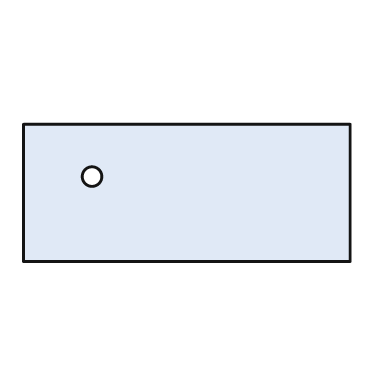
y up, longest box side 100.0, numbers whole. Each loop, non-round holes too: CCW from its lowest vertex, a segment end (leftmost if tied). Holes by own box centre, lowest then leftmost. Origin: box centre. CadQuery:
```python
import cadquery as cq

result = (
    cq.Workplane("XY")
    .moveTo(-50.0, -21.0)
    .lineTo(50.0, -21.0)
    .lineTo(50.0, 21.0)
    .lineTo(-50.0, 21.0)
    .close()
    .moveTo(-29.0, 5.0)
    .circle(3.0)
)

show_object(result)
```